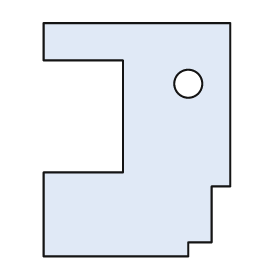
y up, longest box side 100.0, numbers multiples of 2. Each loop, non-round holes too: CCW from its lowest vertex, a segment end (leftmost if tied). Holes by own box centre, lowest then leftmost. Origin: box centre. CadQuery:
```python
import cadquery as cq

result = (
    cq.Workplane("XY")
    .moveTo(-40.0, -50.0)
    .lineTo(22.0, -50.0)
    .lineTo(22.0, -44.0)
    .lineTo(32.0, -44.0)
    .lineTo(32.0, -20.0)
    .lineTo(40.0, -20.0)
    .lineTo(40.0, 50.0)
    .lineTo(-40.0, 50.0)
    .lineTo(-40.0, 34.0)
    .lineTo(-6.0, 34.0)
    .lineTo(-6.0, -14.0)
    .lineTo(-40.0, -14.0)
    .close()
    .moveTo(22.0, 24.0)
    .circle(6.0)
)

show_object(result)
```